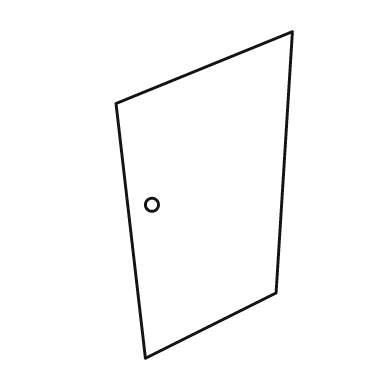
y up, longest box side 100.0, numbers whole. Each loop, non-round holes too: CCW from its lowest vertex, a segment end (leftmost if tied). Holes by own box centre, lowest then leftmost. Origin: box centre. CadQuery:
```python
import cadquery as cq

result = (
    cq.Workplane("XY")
    .moveTo(-18.0, -50.0)
    .lineTo(22.0, -30.0)
    .lineTo(27.0, 50.0)
    .lineTo(-27.0, 28.0)
    .close()
    .moveTo(-16.0, -3.0)
    .circle(2.0)
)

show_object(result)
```